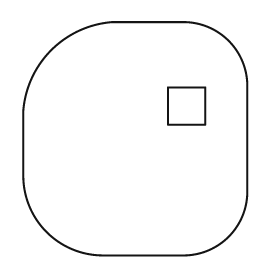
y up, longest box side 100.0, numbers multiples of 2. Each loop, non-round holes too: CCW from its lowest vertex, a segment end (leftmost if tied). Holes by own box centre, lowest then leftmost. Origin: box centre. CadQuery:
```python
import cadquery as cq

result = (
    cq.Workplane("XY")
    .moveTo(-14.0, -50.0)
    .lineTo(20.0, -50.0)
    .threePointArc((40.0, -42.0), (48.0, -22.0))
    .lineTo(48.0, 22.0)
    .threePointArc((40.0, 42.0), (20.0, 50.0))
    .lineTo(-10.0, 50.0)
    .threePointArc((-36.0, 38.0), (-48.0, 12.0))
    .lineTo(-48.0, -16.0)
    .threePointArc((-38.0, -40.0), (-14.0, -50.0))
    .close()
    .moveTo(14.0, 6.0)
    .lineTo(30.0, 6.0)
    .lineTo(30.0, 22.0)
    .lineTo(14.0, 22.0)
    .close()
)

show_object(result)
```